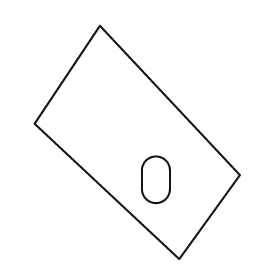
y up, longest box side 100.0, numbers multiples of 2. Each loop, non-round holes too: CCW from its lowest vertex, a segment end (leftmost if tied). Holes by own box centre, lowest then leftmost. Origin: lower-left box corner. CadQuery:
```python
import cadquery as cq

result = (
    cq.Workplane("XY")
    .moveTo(62.0, 0.0)
    .lineTo(88.0, 36.0)
    .lineTo(28.0, 100.0)
    .lineTo(0.0, 58.0)
    .close()
    .moveTo(46.0, 30.0)
    .threePointArc((52.0, 24.0), (58.0, 30.0))
    .lineTo(58.0, 38.0)
    .threePointArc((52.0, 44.0), (46.0, 38.0))
    .close()
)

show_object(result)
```